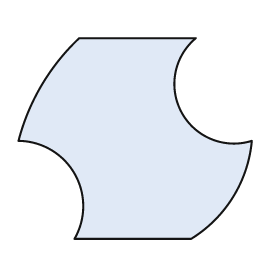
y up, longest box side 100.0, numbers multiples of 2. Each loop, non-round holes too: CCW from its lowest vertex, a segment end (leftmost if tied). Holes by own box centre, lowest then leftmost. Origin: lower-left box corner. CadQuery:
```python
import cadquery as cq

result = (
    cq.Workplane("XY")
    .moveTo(24.0, 0.0)
    .lineTo(74.0, 0.0)
    .threePointArc((92.0, 18.0), (100.0, 42.0))
    .threePointArc((70.0, 54.0), (76.0, 86.0))
    .lineTo(26.0, 86.0)
    .threePointArc((10.0, 66.0), (0.0, 42.0))
    .threePointArc((24.0, 28.0), (24.0, 0.0))
    .close()
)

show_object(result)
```